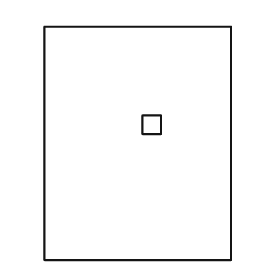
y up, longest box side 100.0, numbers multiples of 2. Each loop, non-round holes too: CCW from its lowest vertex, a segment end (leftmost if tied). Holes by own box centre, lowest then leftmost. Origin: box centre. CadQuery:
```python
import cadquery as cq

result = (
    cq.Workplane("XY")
    .moveTo(-40.0, -50.0)
    .lineTo(40.0, -50.0)
    .lineTo(40.0, 50.0)
    .lineTo(-40.0, 50.0)
    .close()
    .moveTo(2.0, 4.0)
    .lineTo(10.0, 4.0)
    .lineTo(10.0, 12.0)
    .lineTo(2.0, 12.0)
    .close()
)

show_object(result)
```